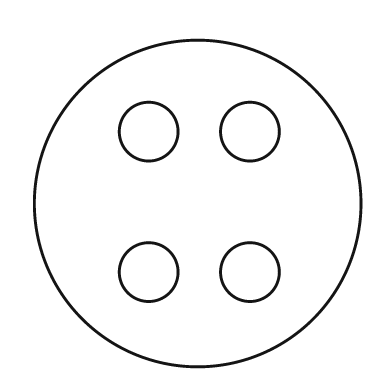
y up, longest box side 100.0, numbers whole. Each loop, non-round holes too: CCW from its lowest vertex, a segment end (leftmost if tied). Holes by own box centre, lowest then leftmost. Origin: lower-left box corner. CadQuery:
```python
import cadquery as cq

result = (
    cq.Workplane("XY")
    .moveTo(50.0, 50.0)
    .circle(50.0)
    .moveTo(35.0, 29.0)
    .circle(9.0)
    .moveTo(66.0, 29.0)
    .circle(9.0)
    .moveTo(35.0, 72.0)
    .circle(9.0)
    .moveTo(66.0, 72.0)
    .circle(9.0)
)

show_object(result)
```